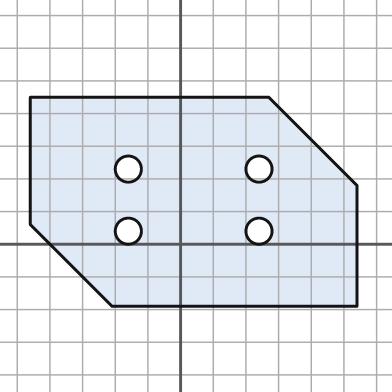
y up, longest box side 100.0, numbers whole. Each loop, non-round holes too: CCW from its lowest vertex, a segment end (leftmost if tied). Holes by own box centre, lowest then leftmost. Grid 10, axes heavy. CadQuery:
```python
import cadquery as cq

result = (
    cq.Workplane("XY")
    .moveTo(-21.0, -19.0)
    .lineTo(54.0, -19.0)
    .lineTo(54.0, 18.0)
    .lineTo(27.0, 45.0)
    .lineTo(-46.0, 45.0)
    .lineTo(-46.0, 6.0)
    .close()
    .moveTo(-16.0, 4.0)
    .circle(4.0)
    .moveTo(24.0, 4.0)
    .circle(4.0)
    .moveTo(-16.0, 23.0)
    .circle(4.0)
    .moveTo(24.0, 23.0)
    .circle(4.0)
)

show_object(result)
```